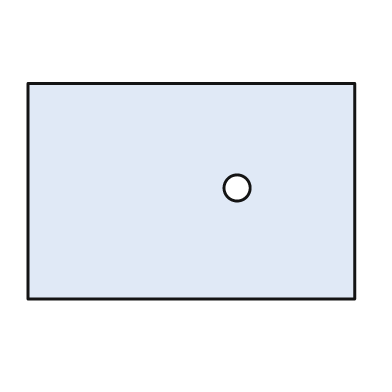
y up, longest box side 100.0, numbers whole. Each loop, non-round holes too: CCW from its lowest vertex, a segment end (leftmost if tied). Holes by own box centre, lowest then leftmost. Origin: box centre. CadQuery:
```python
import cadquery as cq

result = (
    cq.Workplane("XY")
    .moveTo(-50.0, -33.0)
    .lineTo(50.0, -33.0)
    .lineTo(50.0, 33.0)
    .lineTo(-50.0, 33.0)
    .close()
    .moveTo(14.0, 1.0)
    .circle(4.0)
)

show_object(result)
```